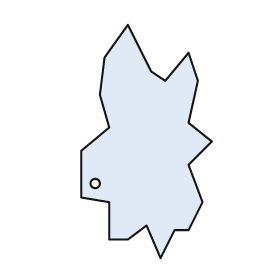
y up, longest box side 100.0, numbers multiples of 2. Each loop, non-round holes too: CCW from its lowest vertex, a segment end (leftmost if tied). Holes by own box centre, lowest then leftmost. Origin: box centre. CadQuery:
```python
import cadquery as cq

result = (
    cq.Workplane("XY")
    .moveTo(6.0, -50.0)
    .lineTo(12.0, -38.0)
    .lineTo(18.0, -38.0)
    .lineTo(24.0, -26.0)
    .lineTo(18.0, -10.0)
    .lineTo(28.0, 0.0)
    .lineTo(18.0, 8.0)
    .lineTo(22.0, 26.0)
    .lineTo(18.0, 38.0)
    .lineTo(8.0, 26.0)
    .lineTo(2.0, 30.0)
    .lineTo(-8.0, 50.0)
    .lineTo(-18.0, 36.0)
    .lineTo(-20.0, 20.0)
    .lineTo(-16.0, 6.0)
    .lineTo(-28.0, -4.0)
    .lineTo(-28.0, -24.0)
    .lineTo(-16.0, -26.0)
    .lineTo(-16.0, -42.0)
    .lineTo(-8.0, -42.0)
    .lineTo(0.0, -36.0)
    .close()
    .moveTo(-22.0, -18.0)
    .circle(2.0)
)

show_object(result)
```